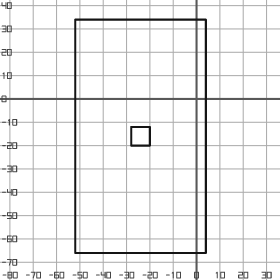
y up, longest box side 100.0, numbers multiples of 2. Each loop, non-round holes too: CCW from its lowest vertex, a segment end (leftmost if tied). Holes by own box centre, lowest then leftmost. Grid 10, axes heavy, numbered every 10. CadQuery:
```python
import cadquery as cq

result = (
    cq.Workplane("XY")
    .moveTo(-52.0, -66.0)
    .lineTo(4.0, -66.0)
    .lineTo(4.0, 34.0)
    .lineTo(-52.0, 34.0)
    .close()
    .moveTo(-28.0, -20.0)
    .lineTo(-20.0, -20.0)
    .lineTo(-20.0, -12.0)
    .lineTo(-28.0, -12.0)
    .close()
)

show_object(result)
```